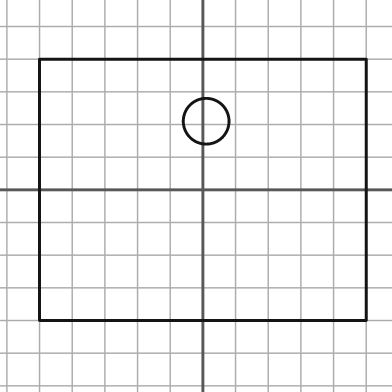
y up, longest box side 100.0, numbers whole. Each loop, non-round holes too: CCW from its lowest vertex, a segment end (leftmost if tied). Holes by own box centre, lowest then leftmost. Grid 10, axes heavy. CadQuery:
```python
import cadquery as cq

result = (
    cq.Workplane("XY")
    .moveTo(-50.0, -40.0)
    .lineTo(50.0, -40.0)
    .lineTo(50.0, 40.0)
    .lineTo(-50.0, 40.0)
    .close()
    .moveTo(1.0, 21.0)
    .circle(7.0)
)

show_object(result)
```